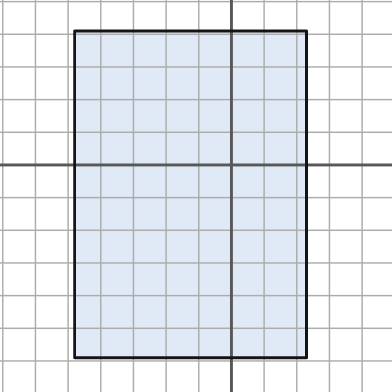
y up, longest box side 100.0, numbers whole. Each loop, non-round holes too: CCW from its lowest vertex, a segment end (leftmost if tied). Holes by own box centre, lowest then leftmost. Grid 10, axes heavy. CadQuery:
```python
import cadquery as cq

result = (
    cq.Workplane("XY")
    .moveTo(-48.0, -59.0)
    .lineTo(23.0, -59.0)
    .lineTo(23.0, 41.0)
    .lineTo(-48.0, 41.0)
    .close()
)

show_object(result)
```